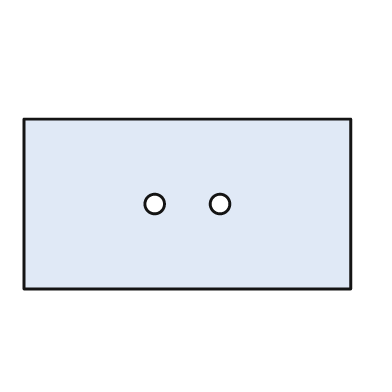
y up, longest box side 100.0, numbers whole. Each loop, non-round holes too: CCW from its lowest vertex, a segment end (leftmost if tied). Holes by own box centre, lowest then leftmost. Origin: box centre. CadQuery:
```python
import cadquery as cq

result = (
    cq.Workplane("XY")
    .moveTo(-50.0, -26.0)
    .lineTo(50.0, -26.0)
    .lineTo(50.0, 26.0)
    .lineTo(-50.0, 26.0)
    .close()
    .moveTo(-10.0, 0.0)
    .circle(3.0)
    .moveTo(10.0, 0.0)
    .circle(3.0)
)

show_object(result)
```